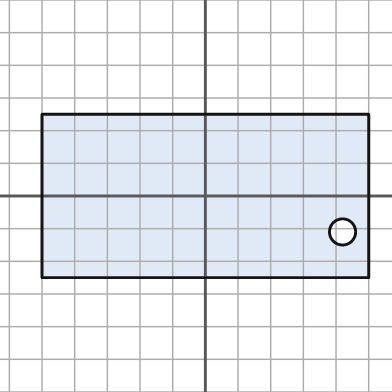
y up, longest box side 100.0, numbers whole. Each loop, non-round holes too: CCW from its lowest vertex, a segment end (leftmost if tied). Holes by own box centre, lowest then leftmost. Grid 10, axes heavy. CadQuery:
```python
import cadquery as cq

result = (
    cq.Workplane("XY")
    .moveTo(-50.0, -25.0)
    .lineTo(50.0, -25.0)
    .lineTo(50.0, 25.0)
    .lineTo(-50.0, 25.0)
    .close()
    .moveTo(42.0, -11.0)
    .circle(4.0)
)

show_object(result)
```